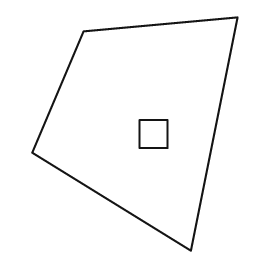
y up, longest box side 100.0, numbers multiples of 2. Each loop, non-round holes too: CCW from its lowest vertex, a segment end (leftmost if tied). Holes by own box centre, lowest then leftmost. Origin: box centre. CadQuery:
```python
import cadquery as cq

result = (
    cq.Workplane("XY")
    .moveTo(24.0, -50.0)
    .lineTo(44.0, 50.0)
    .lineTo(-22.0, 44.0)
    .lineTo(-44.0, -8.0)
    .close()
    .moveTo(2.0, -6.0)
    .lineTo(14.0, -6.0)
    .lineTo(14.0, 6.0)
    .lineTo(2.0, 6.0)
    .close()
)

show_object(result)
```